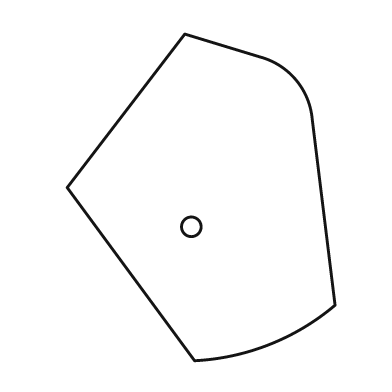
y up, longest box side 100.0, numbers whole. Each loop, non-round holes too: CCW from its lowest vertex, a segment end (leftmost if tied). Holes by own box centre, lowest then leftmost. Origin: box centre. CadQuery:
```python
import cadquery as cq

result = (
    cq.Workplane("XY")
    .moveTo(-2.0, -50.0)
    .threePointArc((21.0, -45.0), (41.0, -33.0))
    .lineTo(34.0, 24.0)
    .threePointArc((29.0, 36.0), (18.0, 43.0))
    .lineTo(-5.0, 50.0)
    .lineTo(-41.0, 3.0)
    .close()
    .moveTo(-3.0, -9.0)
    .circle(3.0)
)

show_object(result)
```